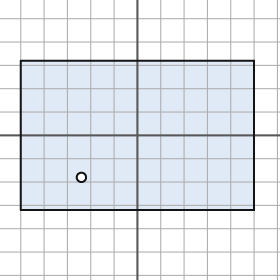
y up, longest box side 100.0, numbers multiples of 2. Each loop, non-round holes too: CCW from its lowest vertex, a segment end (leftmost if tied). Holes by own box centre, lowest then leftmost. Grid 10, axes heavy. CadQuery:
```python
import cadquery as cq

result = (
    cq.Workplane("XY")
    .moveTo(-50.0, -32.0)
    .lineTo(50.0, -32.0)
    .lineTo(50.0, 32.0)
    .lineTo(-50.0, 32.0)
    .close()
    .moveTo(-24.0, -18.0)
    .circle(2.0)
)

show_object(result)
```